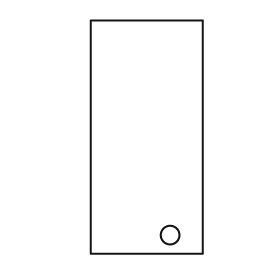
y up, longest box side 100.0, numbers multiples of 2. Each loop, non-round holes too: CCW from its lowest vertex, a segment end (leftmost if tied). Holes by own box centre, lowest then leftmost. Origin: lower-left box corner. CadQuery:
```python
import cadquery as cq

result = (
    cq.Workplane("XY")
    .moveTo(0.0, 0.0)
    .lineTo(48.0, 0.0)
    .lineTo(48.0, 100.0)
    .lineTo(0.0, 100.0)
    .close()
    .moveTo(34.0, 8.0)
    .circle(4.0)
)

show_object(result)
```